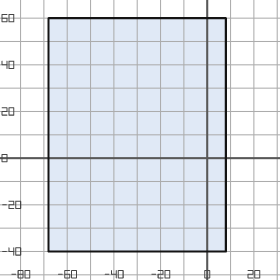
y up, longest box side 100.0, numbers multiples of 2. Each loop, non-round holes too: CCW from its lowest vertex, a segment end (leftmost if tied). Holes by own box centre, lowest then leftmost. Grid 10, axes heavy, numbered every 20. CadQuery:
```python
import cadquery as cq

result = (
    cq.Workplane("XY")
    .moveTo(-68.0, -40.0)
    .lineTo(8.0, -40.0)
    .lineTo(8.0, 60.0)
    .lineTo(-68.0, 60.0)
    .close()
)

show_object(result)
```